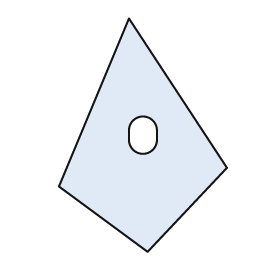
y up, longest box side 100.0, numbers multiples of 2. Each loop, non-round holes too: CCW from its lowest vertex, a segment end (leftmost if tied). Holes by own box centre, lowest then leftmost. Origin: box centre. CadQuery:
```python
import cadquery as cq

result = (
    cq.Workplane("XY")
    .moveTo(2.0, -50.0)
    .lineTo(36.0, -14.0)
    .lineTo(-6.0, 50.0)
    .lineTo(-36.0, -22.0)
    .close()
    .moveTo(-6.0, -2.0)
    .threePointArc((0.0, -8.0), (6.0, -2.0))
    .lineTo(6.0, 2.0)
    .threePointArc((0.0, 8.0), (-6.0, 2.0))
    .close()
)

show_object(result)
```